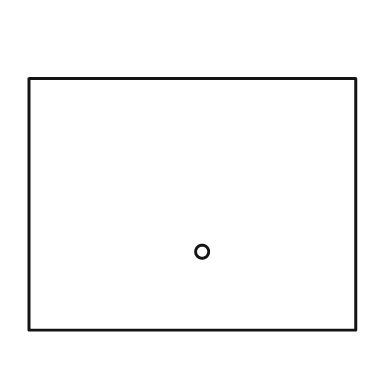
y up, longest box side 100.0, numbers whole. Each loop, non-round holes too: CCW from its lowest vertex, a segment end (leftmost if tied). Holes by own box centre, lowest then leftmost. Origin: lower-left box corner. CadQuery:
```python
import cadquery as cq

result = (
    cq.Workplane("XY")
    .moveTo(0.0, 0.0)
    .lineTo(100.0, 0.0)
    .lineTo(100.0, 77.0)
    .lineTo(0.0, 77.0)
    .close()
    .moveTo(53.0, 24.0)
    .circle(2.0)
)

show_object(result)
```